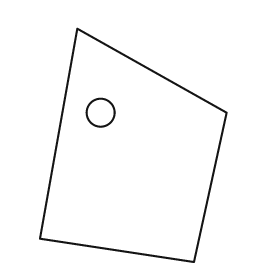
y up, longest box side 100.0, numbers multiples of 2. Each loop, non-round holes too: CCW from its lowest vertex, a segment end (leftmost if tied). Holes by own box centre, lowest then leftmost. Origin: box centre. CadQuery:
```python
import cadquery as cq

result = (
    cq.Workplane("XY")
    .moveTo(26.0, -50.0)
    .lineTo(40.0, 14.0)
    .lineTo(-24.0, 50.0)
    .lineTo(-40.0, -40.0)
    .close()
    .moveTo(-14.0, 14.0)
    .circle(6.0)
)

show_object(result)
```